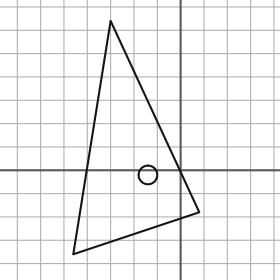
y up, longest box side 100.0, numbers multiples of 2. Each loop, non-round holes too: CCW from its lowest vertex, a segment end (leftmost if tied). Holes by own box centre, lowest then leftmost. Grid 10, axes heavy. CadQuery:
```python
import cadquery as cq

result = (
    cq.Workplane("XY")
    .moveTo(-46.0, -36.0)
    .lineTo(8.0, -18.0)
    .lineTo(-30.0, 64.0)
    .close()
    .moveTo(-14.0, -2.0)
    .circle(4.0)
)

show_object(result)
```